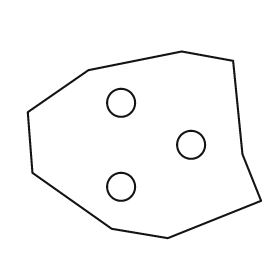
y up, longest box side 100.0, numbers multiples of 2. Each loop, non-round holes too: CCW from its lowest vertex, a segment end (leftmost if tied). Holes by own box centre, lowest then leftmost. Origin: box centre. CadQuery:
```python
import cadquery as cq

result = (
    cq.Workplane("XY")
    .moveTo(10.0, -40.0)
    .lineTo(50.0, -24.0)
    .lineTo(42.0, -4.0)
    .lineTo(38.0, 36.0)
    .lineTo(16.0, 40.0)
    .lineTo(-24.0, 32.0)
    .lineTo(-50.0, 14.0)
    .lineTo(-48.0, -12.0)
    .lineTo(-14.0, -36.0)
    .close()
    .moveTo(-10.0, -18.0)
    .circle(6.0)
    .moveTo(20.0, 0.0)
    .circle(6.0)
    .moveTo(-10.0, 18.0)
    .circle(6.0)
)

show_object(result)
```